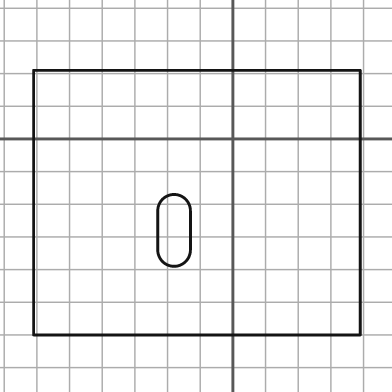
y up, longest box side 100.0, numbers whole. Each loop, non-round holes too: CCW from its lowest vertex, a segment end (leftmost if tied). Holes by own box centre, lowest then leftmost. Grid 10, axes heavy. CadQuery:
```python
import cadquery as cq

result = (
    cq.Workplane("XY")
    .moveTo(-61.0, -60.0)
    .lineTo(39.0, -60.0)
    .lineTo(39.0, 21.0)
    .lineTo(-61.0, 21.0)
    .close()
    .moveTo(-23.0, -34.0)
    .threePointArc((-18.0, -39.0), (-13.0, -34.0))
    .lineTo(-13.0, -22.0)
    .threePointArc((-18.0, -17.0), (-23.0, -22.0))
    .close()
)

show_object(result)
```